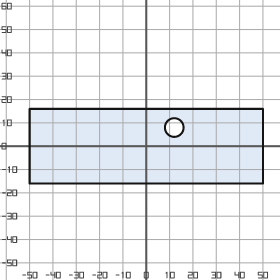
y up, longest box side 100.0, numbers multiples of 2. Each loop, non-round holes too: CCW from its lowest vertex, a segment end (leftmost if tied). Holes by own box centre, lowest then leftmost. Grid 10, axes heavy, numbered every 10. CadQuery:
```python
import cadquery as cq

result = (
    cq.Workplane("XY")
    .moveTo(-50.0, -16.0)
    .lineTo(50.0, -16.0)
    .lineTo(50.0, 16.0)
    .lineTo(-50.0, 16.0)
    .close()
    .moveTo(12.0, 8.0)
    .circle(4.0)
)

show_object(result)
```